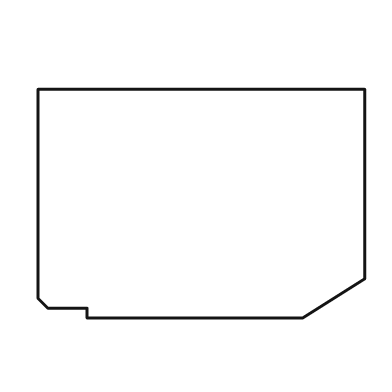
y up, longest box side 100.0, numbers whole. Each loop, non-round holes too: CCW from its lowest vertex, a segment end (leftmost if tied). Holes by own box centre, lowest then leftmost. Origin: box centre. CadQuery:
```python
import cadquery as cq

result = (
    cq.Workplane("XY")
    .moveTo(-35.0, -35.0)
    .lineTo(31.0, -35.0)
    .lineTo(50.0, -23.0)
    .lineTo(50.0, 35.0)
    .lineTo(-50.0, 35.0)
    .lineTo(-50.0, -29.0)
    .lineTo(-47.0, -32.0)
    .lineTo(-35.0, -32.0)
    .close()
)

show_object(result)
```